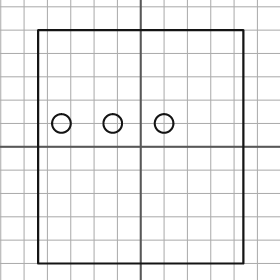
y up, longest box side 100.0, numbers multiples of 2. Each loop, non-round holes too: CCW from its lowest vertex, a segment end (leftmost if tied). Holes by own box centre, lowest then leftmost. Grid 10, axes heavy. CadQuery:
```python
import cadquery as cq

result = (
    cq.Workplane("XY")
    .moveTo(-44.0, -50.0)
    .lineTo(44.0, -50.0)
    .lineTo(44.0, 50.0)
    .lineTo(-44.0, 50.0)
    .close()
    .moveTo(-34.0, 10.0)
    .circle(4.0)
    .moveTo(-12.0, 10.0)
    .circle(4.0)
    .moveTo(10.0, 10.0)
    .circle(4.0)
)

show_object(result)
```